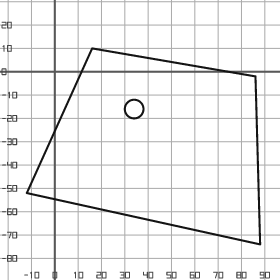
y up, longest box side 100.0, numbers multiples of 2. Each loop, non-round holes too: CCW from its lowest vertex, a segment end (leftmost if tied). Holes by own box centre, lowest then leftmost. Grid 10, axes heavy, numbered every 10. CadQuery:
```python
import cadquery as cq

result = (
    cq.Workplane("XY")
    .moveTo(88.0, -74.0)
    .lineTo(86.0, -2.0)
    .lineTo(16.0, 10.0)
    .lineTo(-12.0, -52.0)
    .close()
    .moveTo(34.0, -16.0)
    .circle(4.0)
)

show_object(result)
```